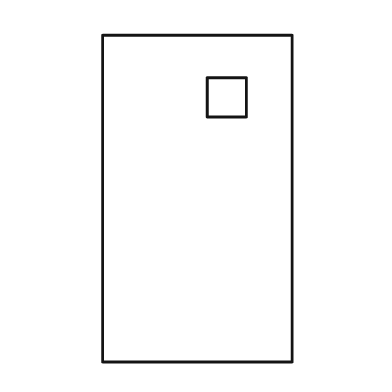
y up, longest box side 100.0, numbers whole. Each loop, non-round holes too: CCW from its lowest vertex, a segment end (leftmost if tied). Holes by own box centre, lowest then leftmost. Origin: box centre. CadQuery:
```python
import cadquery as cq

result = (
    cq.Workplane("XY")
    .moveTo(-29.0, -50.0)
    .lineTo(29.0, -50.0)
    .lineTo(29.0, 50.0)
    .lineTo(-29.0, 50.0)
    .close()
    .moveTo(3.0, 25.0)
    .lineTo(15.0, 25.0)
    .lineTo(15.0, 37.0)
    .lineTo(3.0, 37.0)
    .close()
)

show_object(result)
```